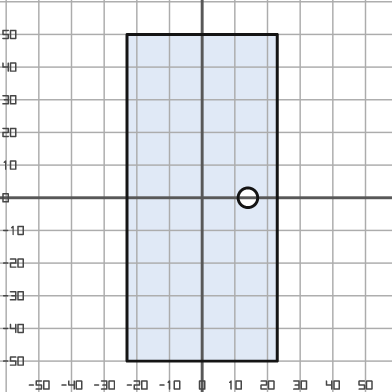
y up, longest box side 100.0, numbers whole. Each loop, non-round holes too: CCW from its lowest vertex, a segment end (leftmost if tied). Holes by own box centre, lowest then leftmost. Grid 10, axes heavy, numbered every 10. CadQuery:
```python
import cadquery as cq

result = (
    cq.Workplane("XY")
    .moveTo(-23.0, -50.0)
    .lineTo(23.0, -50.0)
    .lineTo(23.0, 50.0)
    .lineTo(-23.0, 50.0)
    .close()
    .moveTo(14.0, 0.0)
    .circle(3.0)
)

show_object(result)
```